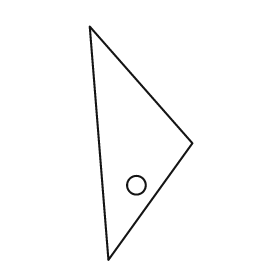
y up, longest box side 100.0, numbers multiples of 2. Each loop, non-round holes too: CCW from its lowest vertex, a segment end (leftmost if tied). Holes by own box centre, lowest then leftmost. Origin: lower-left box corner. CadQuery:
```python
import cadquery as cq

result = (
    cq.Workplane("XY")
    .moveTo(8.0, 0.0)
    .lineTo(44.0, 50.0)
    .lineTo(0.0, 100.0)
    .close()
    .moveTo(20.0, 32.0)
    .circle(4.0)
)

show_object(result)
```